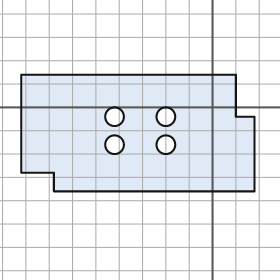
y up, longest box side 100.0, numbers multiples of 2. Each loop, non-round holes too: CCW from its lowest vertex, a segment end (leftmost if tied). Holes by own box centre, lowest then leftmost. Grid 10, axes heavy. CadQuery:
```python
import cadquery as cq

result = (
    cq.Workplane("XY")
    .moveTo(-68.0, -36.0)
    .lineTo(18.0, -36.0)
    .lineTo(18.0, -4.0)
    .lineTo(10.0, -4.0)
    .lineTo(10.0, 14.0)
    .lineTo(-82.0, 14.0)
    .lineTo(-82.0, -28.0)
    .lineTo(-68.0, -28.0)
    .close()
    .moveTo(-42.0, -16.0)
    .circle(4.0)
    .moveTo(-20.0, -16.0)
    .circle(4.0)
    .moveTo(-42.0, -4.0)
    .circle(4.0)
    .moveTo(-20.0, -4.0)
    .circle(4.0)
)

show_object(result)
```